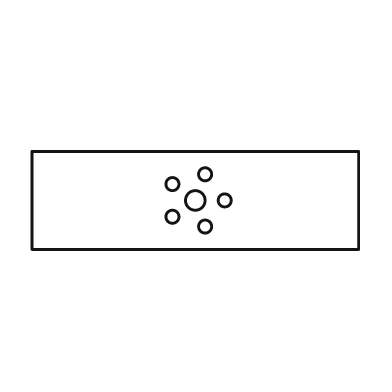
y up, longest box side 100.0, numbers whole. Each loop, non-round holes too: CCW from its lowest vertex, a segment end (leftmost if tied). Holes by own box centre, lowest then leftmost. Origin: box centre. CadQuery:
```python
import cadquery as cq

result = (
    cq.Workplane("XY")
    .moveTo(-50.0, -15.0)
    .lineTo(50.0, -15.0)
    .lineTo(50.0, 15.0)
    .lineTo(-50.0, 15.0)
    .close()
    .moveTo(3.0, -8.0)
    .circle(2.0)
    .moveTo(-7.0, -5.0)
    .circle(2.0)
    .moveTo(0.0, 0.0)
    .circle(3.0)
    .moveTo(9.0, 0.0)
    .circle(2.0)
    .moveTo(-7.0, 5.0)
    .circle(2.0)
    .moveTo(3.0, 8.0)
    .circle(2.0)
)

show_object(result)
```